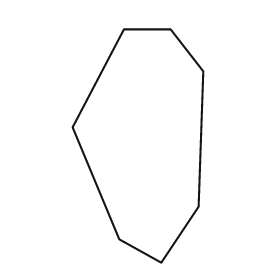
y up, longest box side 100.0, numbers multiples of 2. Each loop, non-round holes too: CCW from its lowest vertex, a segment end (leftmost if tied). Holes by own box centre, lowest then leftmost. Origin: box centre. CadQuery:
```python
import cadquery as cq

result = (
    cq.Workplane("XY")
    .moveTo(10.0, -50.0)
    .lineTo(26.0, -26.0)
    .lineTo(28.0, 32.0)
    .lineTo(14.0, 50.0)
    .lineTo(-6.0, 50.0)
    .lineTo(-28.0, 8.0)
    .lineTo(-8.0, -40.0)
    .close()
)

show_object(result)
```